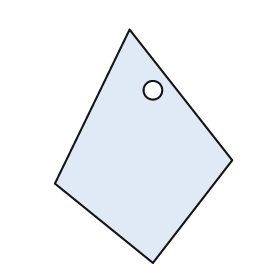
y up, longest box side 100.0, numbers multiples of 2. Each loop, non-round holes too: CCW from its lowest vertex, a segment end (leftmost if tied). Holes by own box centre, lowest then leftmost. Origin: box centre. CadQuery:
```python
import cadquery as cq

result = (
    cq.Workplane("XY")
    .moveTo(4.0, -50.0)
    .lineTo(38.0, -6.0)
    .lineTo(-6.0, 50.0)
    .lineTo(-38.0, -16.0)
    .close()
    .moveTo(4.0, 24.0)
    .circle(4.0)
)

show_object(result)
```